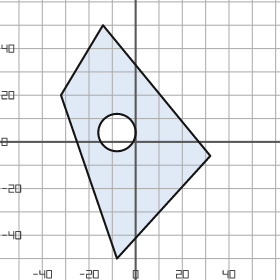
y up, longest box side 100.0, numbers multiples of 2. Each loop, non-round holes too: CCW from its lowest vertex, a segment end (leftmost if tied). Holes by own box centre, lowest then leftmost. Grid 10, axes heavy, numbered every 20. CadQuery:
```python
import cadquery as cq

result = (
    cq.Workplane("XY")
    .moveTo(-8.0, -50.0)
    .lineTo(32.0, -6.0)
    .lineTo(-14.0, 50.0)
    .lineTo(-32.0, 20.0)
    .close()
    .moveTo(-8.0, 4.0)
    .circle(8.0)
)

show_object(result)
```